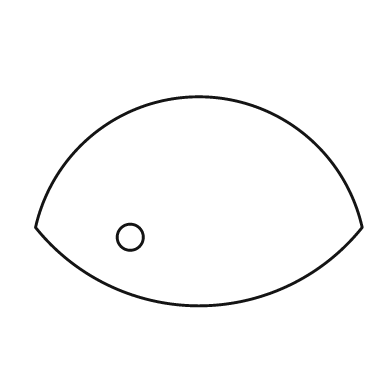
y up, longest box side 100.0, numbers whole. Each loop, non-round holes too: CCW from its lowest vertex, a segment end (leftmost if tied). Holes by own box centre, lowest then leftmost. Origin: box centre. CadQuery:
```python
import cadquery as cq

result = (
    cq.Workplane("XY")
    .moveTo(-50.0, -8.0)
    .threePointArc((0.0, -32.0), (50.0, -8.0))
    .threePointArc((0.0, 32.0), (-50.0, -8.0))
    .close()
    .moveTo(-21.0, -11.0)
    .circle(4.0)
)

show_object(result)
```